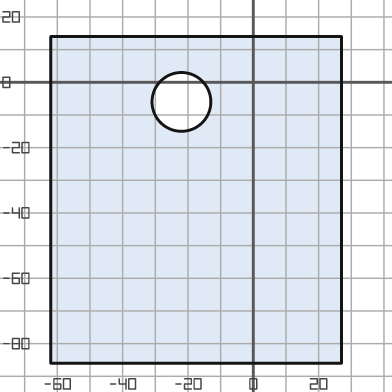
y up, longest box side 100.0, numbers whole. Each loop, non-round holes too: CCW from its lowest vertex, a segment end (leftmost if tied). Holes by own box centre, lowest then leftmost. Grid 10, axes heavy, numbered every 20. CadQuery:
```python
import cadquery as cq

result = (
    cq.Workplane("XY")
    .moveTo(-62.0, -86.0)
    .lineTo(27.0, -86.0)
    .lineTo(27.0, 14.0)
    .lineTo(-62.0, 14.0)
    .close()
    .moveTo(-22.0, -6.0)
    .circle(9.0)
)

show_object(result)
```